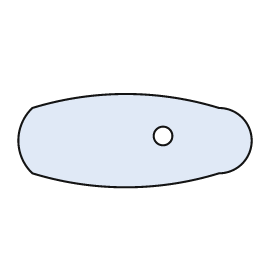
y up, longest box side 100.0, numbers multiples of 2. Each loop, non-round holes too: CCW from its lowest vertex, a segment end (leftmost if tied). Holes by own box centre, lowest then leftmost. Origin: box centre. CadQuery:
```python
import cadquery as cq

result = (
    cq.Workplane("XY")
    .moveTo(-44.0, -14.0)
    .threePointArc((-4.0, -20.0), (36.0, -14.0))
    .threePointArc((50.0, 0.0), (36.0, 14.0))
    .threePointArc((-4.0, 20.0), (-44.0, 14.0))
    .threePointArc((-50.0, 0.0), (-44.0, -14.0))
    .close()
    .moveTo(12.0, 2.0)
    .circle(4.0)
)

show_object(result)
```